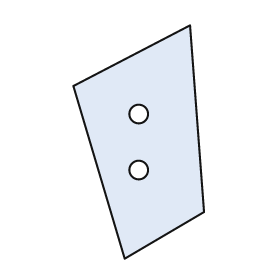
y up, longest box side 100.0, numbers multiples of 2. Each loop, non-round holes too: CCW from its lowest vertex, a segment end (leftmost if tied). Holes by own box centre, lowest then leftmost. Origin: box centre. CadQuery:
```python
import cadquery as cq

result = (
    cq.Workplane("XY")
    .moveTo(-6.0, -50.0)
    .lineTo(28.0, -30.0)
    .lineTo(22.0, 50.0)
    .lineTo(-28.0, 24.0)
    .close()
    .moveTo(0.0, -12.0)
    .circle(4.0)
    .moveTo(0.0, 12.0)
    .circle(4.0)
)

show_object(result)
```